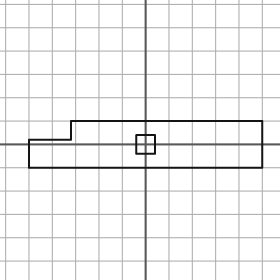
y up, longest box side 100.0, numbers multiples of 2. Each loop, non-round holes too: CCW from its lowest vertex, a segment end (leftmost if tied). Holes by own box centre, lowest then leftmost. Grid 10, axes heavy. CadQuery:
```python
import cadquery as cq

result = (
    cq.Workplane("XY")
    .moveTo(-50.0, -10.0)
    .lineTo(50.0, -10.0)
    .lineTo(50.0, 10.0)
    .lineTo(-32.0, 10.0)
    .lineTo(-32.0, 2.0)
    .lineTo(-50.0, 2.0)
    .close()
    .moveTo(-4.0, -4.0)
    .lineTo(4.0, -4.0)
    .lineTo(4.0, 4.0)
    .lineTo(-4.0, 4.0)
    .close()
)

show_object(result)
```